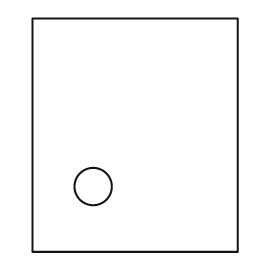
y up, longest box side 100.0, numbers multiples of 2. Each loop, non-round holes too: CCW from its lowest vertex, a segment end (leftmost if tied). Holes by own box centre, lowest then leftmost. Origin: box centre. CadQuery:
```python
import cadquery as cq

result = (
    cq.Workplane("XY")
    .moveTo(-44.0, -50.0)
    .lineTo(44.0, -50.0)
    .lineTo(44.0, 50.0)
    .lineTo(-44.0, 50.0)
    .close()
    .moveTo(-18.0, -22.0)
    .circle(8.0)
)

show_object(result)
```